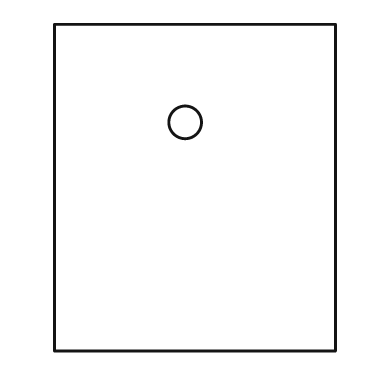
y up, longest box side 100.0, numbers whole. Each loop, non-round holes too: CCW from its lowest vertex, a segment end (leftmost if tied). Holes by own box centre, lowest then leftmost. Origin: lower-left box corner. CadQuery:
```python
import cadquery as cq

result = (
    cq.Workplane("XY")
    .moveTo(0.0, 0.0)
    .lineTo(86.0, 0.0)
    .lineTo(86.0, 100.0)
    .lineTo(0.0, 100.0)
    .close()
    .moveTo(40.0, 70.0)
    .circle(5.0)
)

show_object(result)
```